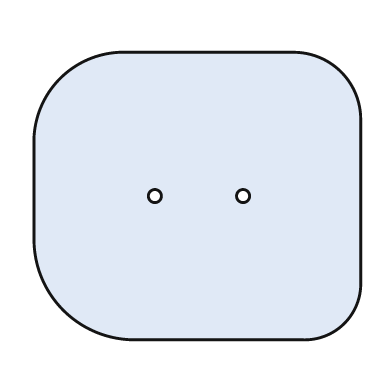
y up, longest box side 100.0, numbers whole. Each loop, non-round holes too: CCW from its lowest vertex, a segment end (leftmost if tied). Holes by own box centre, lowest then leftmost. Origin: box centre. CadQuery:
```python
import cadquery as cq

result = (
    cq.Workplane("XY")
    .moveTo(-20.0, -44.0)
    .lineTo(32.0, -44.0)
    .threePointArc((45.0, -39.0), (50.0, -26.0))
    .lineTo(50.0, 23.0)
    .threePointArc((44.0, 38.0), (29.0, 44.0))
    .lineTo(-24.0, 44.0)
    .threePointArc((-42.0, 36.0), (-50.0, 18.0))
    .lineTo(-50.0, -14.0)
    .threePointArc((-41.0, -35.0), (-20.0, -44.0))
    .close()
    .moveTo(-13.0, 0.0)
    .circle(2.0)
    .moveTo(14.0, 0.0)
    .circle(2.0)
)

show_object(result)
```